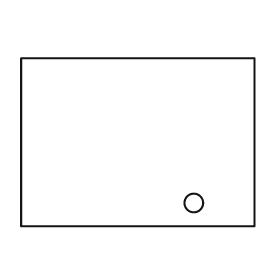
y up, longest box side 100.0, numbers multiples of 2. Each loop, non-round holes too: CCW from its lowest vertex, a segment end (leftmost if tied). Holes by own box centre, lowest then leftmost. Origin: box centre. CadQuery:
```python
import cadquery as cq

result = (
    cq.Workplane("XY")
    .moveTo(-50.0, -36.0)
    .lineTo(50.0, -36.0)
    .lineTo(50.0, 36.0)
    .lineTo(-50.0, 36.0)
    .close()
    .moveTo(24.0, -26.0)
    .circle(4.0)
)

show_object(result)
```